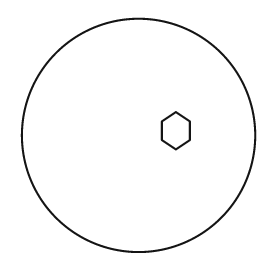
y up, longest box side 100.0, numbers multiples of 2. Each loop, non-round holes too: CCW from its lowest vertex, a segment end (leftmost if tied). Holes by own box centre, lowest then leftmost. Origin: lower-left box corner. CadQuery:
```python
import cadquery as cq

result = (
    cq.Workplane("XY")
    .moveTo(50.0, 50.0)
    .circle(50.0)
    .moveTo(66.0, 44.0)
    .lineTo(72.0, 48.0)
    .lineTo(72.0, 56.0)
    .lineTo(66.0, 60.0)
    .lineTo(60.0, 56.0)
    .lineTo(60.0, 48.0)
    .close()
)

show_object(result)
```